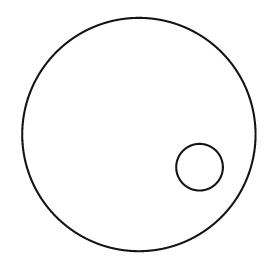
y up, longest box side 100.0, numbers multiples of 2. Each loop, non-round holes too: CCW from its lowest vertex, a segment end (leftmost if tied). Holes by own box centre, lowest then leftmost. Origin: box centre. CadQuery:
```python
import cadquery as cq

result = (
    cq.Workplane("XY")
    .moveTo(0.0, 0.0)
    .circle(50.0)
    .moveTo(26.0, -14.0)
    .circle(10.0)
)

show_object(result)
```